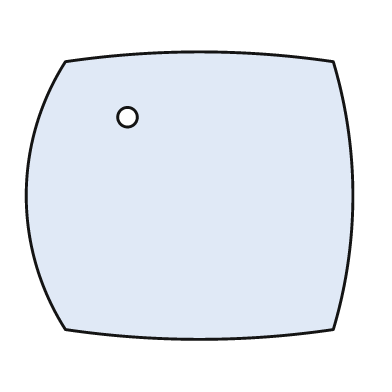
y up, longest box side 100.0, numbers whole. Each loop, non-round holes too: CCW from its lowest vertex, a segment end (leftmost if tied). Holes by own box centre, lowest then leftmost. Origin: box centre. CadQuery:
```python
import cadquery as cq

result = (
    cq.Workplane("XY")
    .moveTo(-38.0, -41.0)
    .threePointArc((3.0, -44.0), (44.0, -41.0))
    .threePointArc((50.0, 0.0), (44.0, 41.0))
    .threePointArc((3.0, 44.0), (-38.0, 41.0))
    .threePointArc((-50.0, 0.0), (-38.0, -41.0))
    .close()
    .moveTo(-19.0, 24.0)
    .circle(3.0)
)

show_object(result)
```